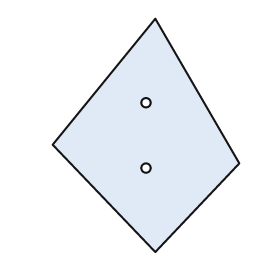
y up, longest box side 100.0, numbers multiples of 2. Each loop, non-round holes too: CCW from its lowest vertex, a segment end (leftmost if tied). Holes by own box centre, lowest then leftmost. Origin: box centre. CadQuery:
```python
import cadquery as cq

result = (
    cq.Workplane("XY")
    .moveTo(4.0, -50.0)
    .lineTo(40.0, -12.0)
    .lineTo(4.0, 50.0)
    .lineTo(-40.0, -4.0)
    .close()
    .moveTo(0.0, -14.0)
    .circle(2.0)
    .moveTo(0.0, 14.0)
    .circle(2.0)
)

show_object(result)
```